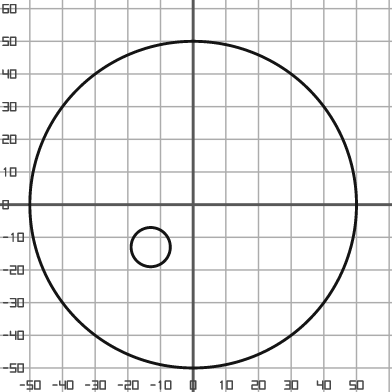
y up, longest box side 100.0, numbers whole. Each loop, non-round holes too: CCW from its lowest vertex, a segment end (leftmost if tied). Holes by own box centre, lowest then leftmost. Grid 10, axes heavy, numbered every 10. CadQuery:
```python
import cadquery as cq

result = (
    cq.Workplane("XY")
    .moveTo(0.0, 0.0)
    .circle(50.0)
    .moveTo(-13.0, -13.0)
    .circle(6.0)
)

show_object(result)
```